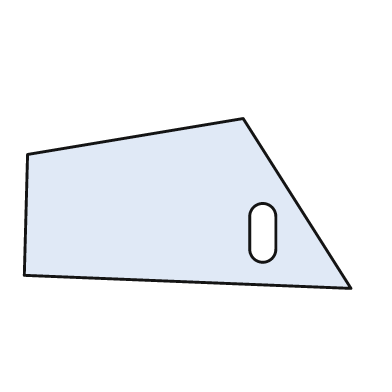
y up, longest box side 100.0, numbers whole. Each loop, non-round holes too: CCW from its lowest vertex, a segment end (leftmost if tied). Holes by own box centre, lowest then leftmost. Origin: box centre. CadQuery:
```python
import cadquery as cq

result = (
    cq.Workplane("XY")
    .moveTo(50.0, -26.0)
    .lineTo(17.0, 26.0)
    .lineTo(-49.0, 15.0)
    .lineTo(-50.0, -22.0)
    .close()
    .moveTo(19.0, -14.0)
    .threePointArc((23.0, -18.0), (27.0, -14.0))
    .lineTo(27.0, -4.0)
    .threePointArc((23.0, 0.0), (19.0, -4.0))
    .close()
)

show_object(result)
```